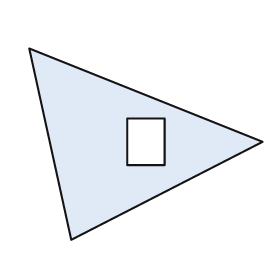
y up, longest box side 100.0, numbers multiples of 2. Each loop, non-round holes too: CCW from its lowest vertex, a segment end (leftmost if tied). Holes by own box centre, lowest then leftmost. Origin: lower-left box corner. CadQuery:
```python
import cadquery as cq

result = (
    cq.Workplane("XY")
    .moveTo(18.0, 0.0)
    .lineTo(100.0, 42.0)
    .lineTo(0.0, 82.0)
    .close()
    .moveTo(42.0, 32.0)
    .lineTo(58.0, 32.0)
    .lineTo(58.0, 52.0)
    .lineTo(42.0, 52.0)
    .close()
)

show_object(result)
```